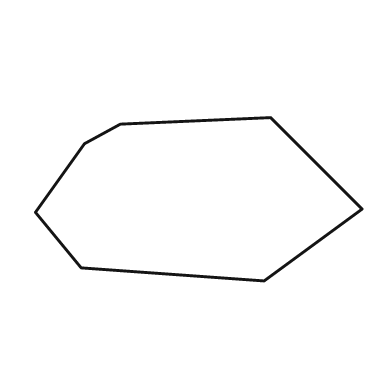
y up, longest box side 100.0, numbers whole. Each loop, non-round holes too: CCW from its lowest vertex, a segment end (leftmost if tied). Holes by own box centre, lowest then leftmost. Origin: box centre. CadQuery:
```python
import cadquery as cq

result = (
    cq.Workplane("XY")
    .moveTo(20.0, -25.0)
    .lineTo(50.0, -3.0)
    .lineTo(22.0, 25.0)
    .lineTo(-24.0, 23.0)
    .lineTo(-35.0, 17.0)
    .lineTo(-50.0, -4.0)
    .lineTo(-36.0, -21.0)
    .close()
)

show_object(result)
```